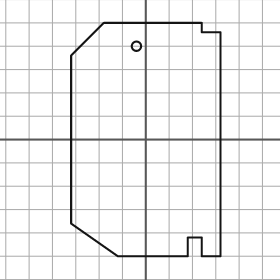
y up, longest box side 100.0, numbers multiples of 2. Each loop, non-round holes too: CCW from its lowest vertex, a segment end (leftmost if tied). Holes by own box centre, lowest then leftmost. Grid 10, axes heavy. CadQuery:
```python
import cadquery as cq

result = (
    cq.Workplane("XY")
    .moveTo(-12.0, -50.0)
    .lineTo(18.0, -50.0)
    .lineTo(18.0, -42.0)
    .lineTo(24.0, -42.0)
    .lineTo(24.0, -50.0)
    .lineTo(32.0, -50.0)
    .lineTo(32.0, 46.0)
    .lineTo(24.0, 46.0)
    .lineTo(24.0, 50.0)
    .lineTo(-18.0, 50.0)
    .lineTo(-32.0, 36.0)
    .lineTo(-32.0, -36.0)
    .close()
    .moveTo(-4.0, 40.0)
    .circle(2.0)
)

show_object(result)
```